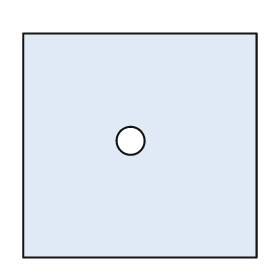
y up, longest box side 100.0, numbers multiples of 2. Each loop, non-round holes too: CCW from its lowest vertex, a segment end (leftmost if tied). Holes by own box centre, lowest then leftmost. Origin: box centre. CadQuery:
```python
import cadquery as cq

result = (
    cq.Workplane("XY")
    .moveTo(-50.0, -48.0)
    .lineTo(50.0, -48.0)
    .lineTo(50.0, 48.0)
    .lineTo(-50.0, 48.0)
    .close()
    .moveTo(-4.0, 2.0)
    .circle(6.0)
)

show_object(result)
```